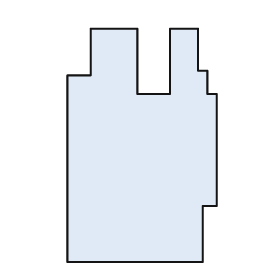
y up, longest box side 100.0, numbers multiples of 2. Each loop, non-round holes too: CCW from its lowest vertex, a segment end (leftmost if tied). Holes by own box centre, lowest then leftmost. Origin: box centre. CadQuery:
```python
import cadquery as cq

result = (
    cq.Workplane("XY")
    .moveTo(-32.0, -50.0)
    .lineTo(26.0, -50.0)
    .lineTo(26.0, -26.0)
    .lineTo(32.0, -26.0)
    .lineTo(32.0, 22.0)
    .lineTo(28.0, 22.0)
    .lineTo(28.0, 32.0)
    .lineTo(24.0, 32.0)
    .lineTo(24.0, 50.0)
    .lineTo(12.0, 50.0)
    .lineTo(12.0, 22.0)
    .lineTo(-2.0, 22.0)
    .lineTo(-2.0, 50.0)
    .lineTo(-22.0, 50.0)
    .lineTo(-22.0, 30.0)
    .lineTo(-32.0, 30.0)
    .close()
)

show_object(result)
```